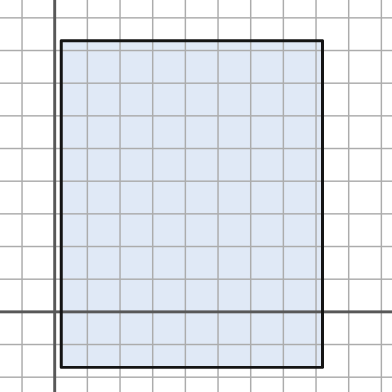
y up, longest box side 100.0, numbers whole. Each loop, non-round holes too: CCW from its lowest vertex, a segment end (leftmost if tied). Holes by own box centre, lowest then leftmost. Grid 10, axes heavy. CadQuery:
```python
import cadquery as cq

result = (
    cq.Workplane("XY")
    .moveTo(2.0, -17.0)
    .lineTo(82.0, -17.0)
    .lineTo(82.0, 83.0)
    .lineTo(2.0, 83.0)
    .close()
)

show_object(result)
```